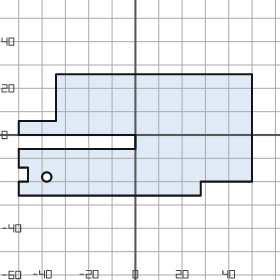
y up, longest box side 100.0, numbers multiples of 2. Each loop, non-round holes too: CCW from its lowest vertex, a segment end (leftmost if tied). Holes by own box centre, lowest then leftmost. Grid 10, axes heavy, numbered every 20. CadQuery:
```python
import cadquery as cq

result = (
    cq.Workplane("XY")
    .moveTo(-50.0, -26.0)
    .lineTo(28.0, -26.0)
    .lineTo(28.0, -20.0)
    .lineTo(50.0, -20.0)
    .lineTo(50.0, 26.0)
    .lineTo(-34.0, 26.0)
    .lineTo(-34.0, 6.0)
    .lineTo(-50.0, 6.0)
    .lineTo(-50.0, 0.0)
    .lineTo(0.0, 0.0)
    .lineTo(0.0, -6.0)
    .lineTo(-50.0, -6.0)
    .lineTo(-50.0, -14.0)
    .lineTo(-46.0, -14.0)
    .lineTo(-46.0, -20.0)
    .lineTo(-50.0, -20.0)
    .close()
    .moveTo(-38.0, -18.0)
    .circle(2.0)
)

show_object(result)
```